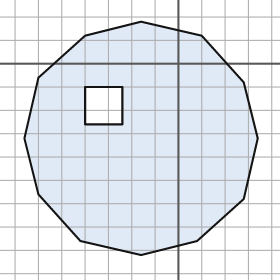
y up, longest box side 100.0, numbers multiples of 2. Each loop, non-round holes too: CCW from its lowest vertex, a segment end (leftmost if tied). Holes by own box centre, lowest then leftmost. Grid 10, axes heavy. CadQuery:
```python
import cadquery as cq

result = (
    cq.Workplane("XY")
    .moveTo(-16.0, -82.0)
    .lineTo(8.0, -76.0)
    .lineTo(28.0, -58.0)
    .lineTo(34.0, -32.0)
    .lineTo(28.0, -8.0)
    .lineTo(10.0, 12.0)
    .lineTo(-16.0, 18.0)
    .lineTo(-40.0, 12.0)
    .lineTo(-60.0, -6.0)
    .lineTo(-66.0, -32.0)
    .lineTo(-60.0, -56.0)
    .lineTo(-42.0, -76.0)
    .close()
    .moveTo(-40.0, -26.0)
    .lineTo(-24.0, -26.0)
    .lineTo(-24.0, -10.0)
    .lineTo(-40.0, -10.0)
    .close()
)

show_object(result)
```